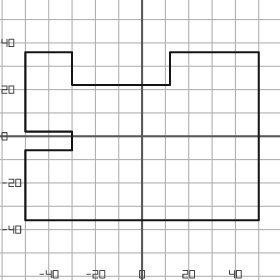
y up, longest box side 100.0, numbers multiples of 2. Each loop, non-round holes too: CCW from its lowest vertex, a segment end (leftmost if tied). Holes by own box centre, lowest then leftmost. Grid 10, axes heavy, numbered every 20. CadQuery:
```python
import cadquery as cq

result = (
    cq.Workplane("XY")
    .moveTo(-50.0, -36.0)
    .lineTo(50.0, -36.0)
    .lineTo(50.0, 36.0)
    .lineTo(12.0, 36.0)
    .lineTo(12.0, 22.0)
    .lineTo(-30.0, 22.0)
    .lineTo(-30.0, 36.0)
    .lineTo(-50.0, 36.0)
    .lineTo(-50.0, 2.0)
    .lineTo(-30.0, 2.0)
    .lineTo(-30.0, -6.0)
    .lineTo(-50.0, -6.0)
    .close()
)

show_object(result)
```